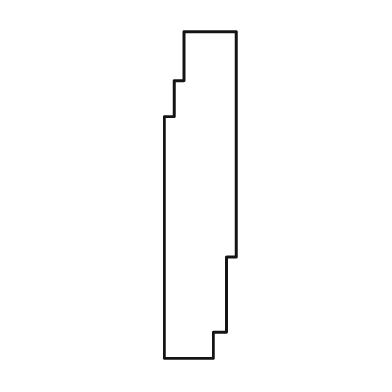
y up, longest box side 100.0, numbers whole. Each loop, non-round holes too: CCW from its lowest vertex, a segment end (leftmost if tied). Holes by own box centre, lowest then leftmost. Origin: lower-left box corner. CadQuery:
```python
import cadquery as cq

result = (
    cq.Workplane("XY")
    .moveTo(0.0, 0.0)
    .lineTo(15.0, 0.0)
    .lineTo(15.0, 8.0)
    .lineTo(19.0, 8.0)
    .lineTo(19.0, 31.0)
    .lineTo(22.0, 31.0)
    .lineTo(22.0, 100.0)
    .lineTo(6.0, 100.0)
    .lineTo(6.0, 85.0)
    .lineTo(3.0, 85.0)
    .lineTo(3.0, 74.0)
    .lineTo(0.0, 74.0)
    .close()
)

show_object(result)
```